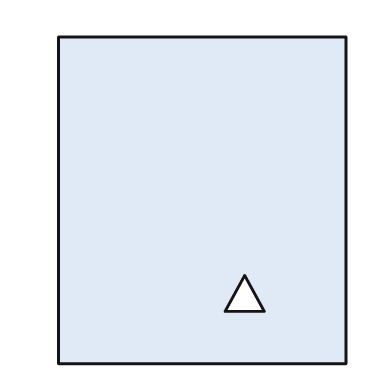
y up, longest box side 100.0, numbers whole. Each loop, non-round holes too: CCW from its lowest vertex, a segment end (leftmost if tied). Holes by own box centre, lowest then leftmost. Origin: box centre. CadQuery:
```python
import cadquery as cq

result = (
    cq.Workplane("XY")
    .moveTo(-44.0, -50.0)
    .lineTo(44.0, -50.0)
    .lineTo(44.0, 50.0)
    .lineTo(-44.0, 50.0)
    .close()
    .moveTo(7.0, -34.0)
    .lineTo(19.0, -34.0)
    .lineTo(13.0, -23.0)
    .close()
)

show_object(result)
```